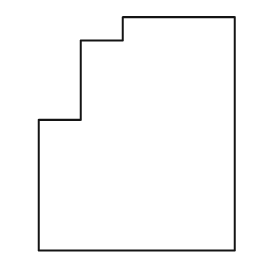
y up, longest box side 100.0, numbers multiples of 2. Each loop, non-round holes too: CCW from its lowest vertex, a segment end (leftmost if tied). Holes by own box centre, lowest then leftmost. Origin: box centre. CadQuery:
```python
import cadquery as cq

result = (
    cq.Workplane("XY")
    .moveTo(-42.0, -50.0)
    .lineTo(42.0, -50.0)
    .lineTo(42.0, 50.0)
    .lineTo(-6.0, 50.0)
    .lineTo(-6.0, 40.0)
    .lineTo(-24.0, 40.0)
    .lineTo(-24.0, 6.0)
    .lineTo(-42.0, 6.0)
    .close()
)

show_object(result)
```